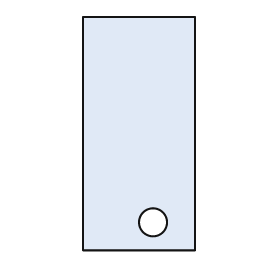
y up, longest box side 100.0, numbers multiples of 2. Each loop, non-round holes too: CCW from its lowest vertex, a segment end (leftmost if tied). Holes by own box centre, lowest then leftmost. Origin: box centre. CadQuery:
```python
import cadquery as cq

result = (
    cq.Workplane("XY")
    .moveTo(-24.0, -50.0)
    .lineTo(24.0, -50.0)
    .lineTo(24.0, 50.0)
    .lineTo(-24.0, 50.0)
    .close()
    .moveTo(6.0, -38.0)
    .circle(6.0)
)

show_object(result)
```